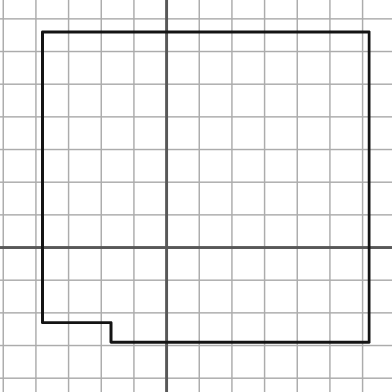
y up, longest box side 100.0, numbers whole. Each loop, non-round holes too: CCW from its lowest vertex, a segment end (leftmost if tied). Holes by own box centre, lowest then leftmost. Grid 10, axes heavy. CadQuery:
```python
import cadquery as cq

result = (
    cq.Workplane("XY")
    .moveTo(-17.0, -29.0)
    .lineTo(62.0, -29.0)
    .lineTo(62.0, 66.0)
    .lineTo(-38.0, 66.0)
    .lineTo(-38.0, -23.0)
    .lineTo(-17.0, -23.0)
    .close()
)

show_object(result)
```